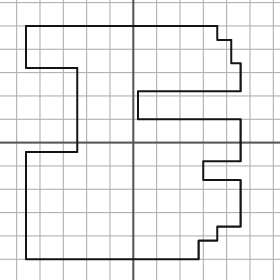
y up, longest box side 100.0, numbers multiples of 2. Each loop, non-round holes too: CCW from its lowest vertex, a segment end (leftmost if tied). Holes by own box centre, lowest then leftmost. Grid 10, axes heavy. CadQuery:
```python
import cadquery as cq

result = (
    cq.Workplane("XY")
    .moveTo(-46.0, -50.0)
    .lineTo(28.0, -50.0)
    .lineTo(28.0, -42.0)
    .lineTo(36.0, -42.0)
    .lineTo(36.0, -36.0)
    .lineTo(46.0, -36.0)
    .lineTo(46.0, -16.0)
    .lineTo(30.0, -16.0)
    .lineTo(30.0, -8.0)
    .lineTo(46.0, -8.0)
    .lineTo(46.0, 10.0)
    .lineTo(2.0, 10.0)
    .lineTo(2.0, 22.0)
    .lineTo(46.0, 22.0)
    .lineTo(46.0, 34.0)
    .lineTo(42.0, 34.0)
    .lineTo(42.0, 44.0)
    .lineTo(36.0, 44.0)
    .lineTo(36.0, 50.0)
    .lineTo(-46.0, 50.0)
    .lineTo(-46.0, 32.0)
    .lineTo(-24.0, 32.0)
    .lineTo(-24.0, -4.0)
    .lineTo(-46.0, -4.0)
    .close()
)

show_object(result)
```